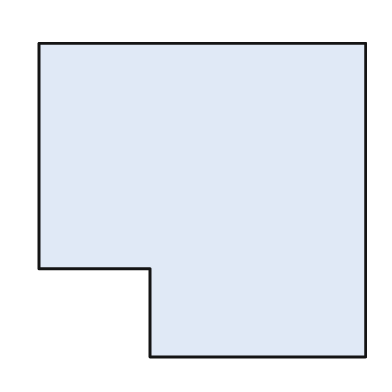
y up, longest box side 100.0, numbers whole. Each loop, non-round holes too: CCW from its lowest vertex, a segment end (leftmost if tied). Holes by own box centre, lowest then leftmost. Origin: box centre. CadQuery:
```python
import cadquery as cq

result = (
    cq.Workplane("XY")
    .moveTo(-16.0, -48.0)
    .lineTo(50.0, -48.0)
    .lineTo(50.0, 48.0)
    .lineTo(-50.0, 48.0)
    .lineTo(-50.0, -21.0)
    .lineTo(-16.0, -21.0)
    .close()
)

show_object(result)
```